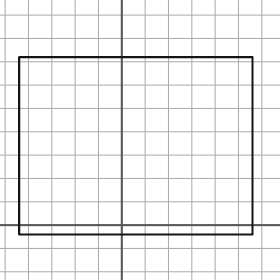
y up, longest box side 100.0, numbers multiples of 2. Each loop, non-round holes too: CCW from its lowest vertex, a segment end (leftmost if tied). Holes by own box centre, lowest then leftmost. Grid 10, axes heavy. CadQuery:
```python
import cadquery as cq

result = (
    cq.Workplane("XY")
    .moveTo(-44.0, -4.0)
    .lineTo(56.0, -4.0)
    .lineTo(56.0, 72.0)
    .lineTo(-44.0, 72.0)
    .close()
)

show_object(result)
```